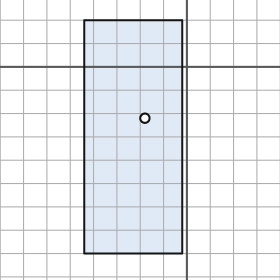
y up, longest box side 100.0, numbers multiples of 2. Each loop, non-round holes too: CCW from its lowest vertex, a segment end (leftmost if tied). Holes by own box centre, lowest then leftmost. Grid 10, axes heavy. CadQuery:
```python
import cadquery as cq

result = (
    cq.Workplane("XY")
    .moveTo(-44.0, -80.0)
    .lineTo(-2.0, -80.0)
    .lineTo(-2.0, 20.0)
    .lineTo(-44.0, 20.0)
    .close()
    .moveTo(-18.0, -22.0)
    .circle(2.0)
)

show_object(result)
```